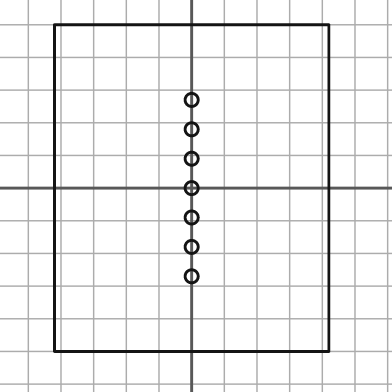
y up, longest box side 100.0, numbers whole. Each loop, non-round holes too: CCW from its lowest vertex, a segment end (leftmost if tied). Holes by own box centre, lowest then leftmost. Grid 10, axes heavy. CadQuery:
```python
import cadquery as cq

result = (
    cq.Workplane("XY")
    .moveTo(-42.0, -50.0)
    .lineTo(42.0, -50.0)
    .lineTo(42.0, 50.0)
    .lineTo(-42.0, 50.0)
    .close()
    .moveTo(0.0, -27.0)
    .circle(2.0)
    .moveTo(0.0, -18.0)
    .circle(2.0)
    .moveTo(0.0, -9.0)
    .circle(2.0)
    .moveTo(0.0, 0.0)
    .circle(2.0)
    .moveTo(0.0, 9.0)
    .circle(2.0)
    .moveTo(0.0, 18.0)
    .circle(2.0)
    .moveTo(0.0, 27.0)
    .circle(2.0)
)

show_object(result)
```